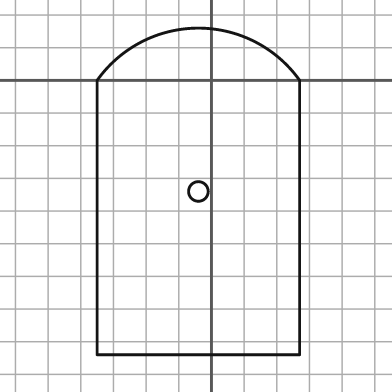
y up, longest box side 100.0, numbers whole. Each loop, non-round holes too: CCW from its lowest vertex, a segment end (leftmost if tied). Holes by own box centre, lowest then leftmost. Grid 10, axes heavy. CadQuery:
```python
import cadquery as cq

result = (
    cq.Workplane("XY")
    .moveTo(-35.0, -84.0)
    .lineTo(27.0, -84.0)
    .lineTo(27.0, 0.0)
    .threePointArc((-4.0, 16.0), (-35.0, 0.0))
    .close()
    .moveTo(-4.0, -34.0)
    .circle(3.0)
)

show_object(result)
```